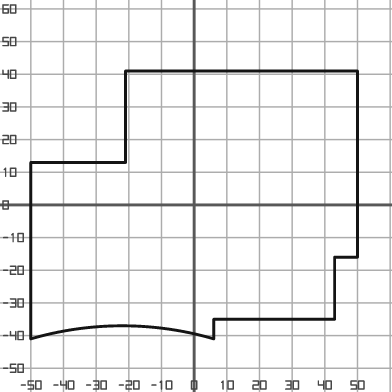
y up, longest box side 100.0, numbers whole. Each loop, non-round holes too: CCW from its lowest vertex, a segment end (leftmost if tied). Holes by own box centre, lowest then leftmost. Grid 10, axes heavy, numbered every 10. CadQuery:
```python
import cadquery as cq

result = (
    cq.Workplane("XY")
    .moveTo(-50.0, -41.0)
    .threePointArc((-22.0, -37.0), (6.0, -41.0))
    .lineTo(6.0, -35.0)
    .lineTo(43.0, -35.0)
    .lineTo(43.0, -16.0)
    .lineTo(50.0, -16.0)
    .lineTo(50.0, 41.0)
    .lineTo(-21.0, 41.0)
    .lineTo(-21.0, 13.0)
    .lineTo(-50.0, 13.0)
    .close()
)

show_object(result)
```